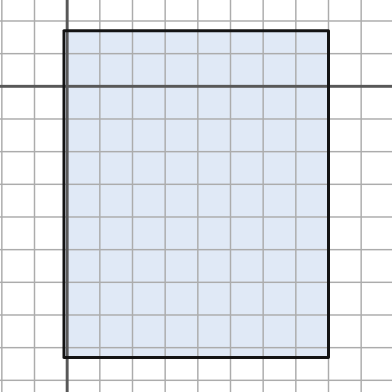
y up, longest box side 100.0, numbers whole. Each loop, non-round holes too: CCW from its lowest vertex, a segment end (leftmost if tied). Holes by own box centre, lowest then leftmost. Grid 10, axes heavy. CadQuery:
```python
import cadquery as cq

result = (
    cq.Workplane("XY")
    .moveTo(-1.0, -83.0)
    .lineTo(80.0, -83.0)
    .lineTo(80.0, 17.0)
    .lineTo(-1.0, 17.0)
    .close()
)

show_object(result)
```